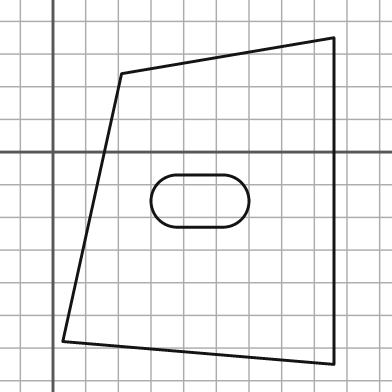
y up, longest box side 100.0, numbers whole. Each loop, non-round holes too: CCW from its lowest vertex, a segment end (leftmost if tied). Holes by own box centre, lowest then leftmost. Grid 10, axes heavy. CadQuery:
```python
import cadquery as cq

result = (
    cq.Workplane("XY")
    .moveTo(86.0, -65.0)
    .lineTo(86.0, 35.0)
    .lineTo(21.0, 24.0)
    .lineTo(3.0, -58.0)
    .close()
    .moveTo(38.0, -23.0)
    .lineTo(52.0, -23.0)
    .threePointArc((60.0, -15.0), (52.0, -7.0))
    .lineTo(38.0, -7.0)
    .threePointArc((30.0, -15.0), (38.0, -23.0))
    .close()
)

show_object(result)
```